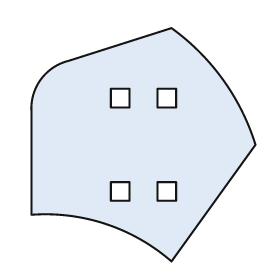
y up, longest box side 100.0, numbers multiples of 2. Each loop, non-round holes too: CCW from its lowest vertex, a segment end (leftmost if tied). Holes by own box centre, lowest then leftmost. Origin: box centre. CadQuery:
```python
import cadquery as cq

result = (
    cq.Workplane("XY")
    .moveTo(12.0, -50.0)
    .lineTo(48.0, 0.0)
    .threePointArc((34.0, 28.0), (12.0, 50.0))
    .lineTo(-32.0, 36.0)
    .threePointArc((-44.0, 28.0), (-48.0, 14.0))
    .lineTo(-48.0, -30.0)
    .threePointArc((-16.0, -34.0), (12.0, -50.0))
    .close()
    .moveTo(-14.0, -24.0)
    .lineTo(-6.0, -24.0)
    .lineTo(-6.0, -16.0)
    .lineTo(-14.0, -16.0)
    .close()
    .moveTo(6.0, -24.0)
    .lineTo(14.0, -24.0)
    .lineTo(14.0, -16.0)
    .lineTo(6.0, -16.0)
    .close()
    .moveTo(-14.0, 16.0)
    .lineTo(-6.0, 16.0)
    .lineTo(-6.0, 24.0)
    .lineTo(-14.0, 24.0)
    .close()
    .moveTo(6.0, 16.0)
    .lineTo(14.0, 16.0)
    .lineTo(14.0, 24.0)
    .lineTo(6.0, 24.0)
    .close()
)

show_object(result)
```